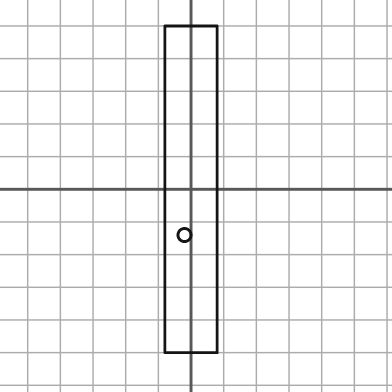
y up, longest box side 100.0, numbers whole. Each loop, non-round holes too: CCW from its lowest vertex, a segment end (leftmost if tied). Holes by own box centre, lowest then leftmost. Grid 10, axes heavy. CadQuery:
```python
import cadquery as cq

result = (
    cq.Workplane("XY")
    .moveTo(-8.0, -50.0)
    .lineTo(8.0, -50.0)
    .lineTo(8.0, 50.0)
    .lineTo(-8.0, 50.0)
    .close()
    .moveTo(-2.0, -14.0)
    .circle(2.0)
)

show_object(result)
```